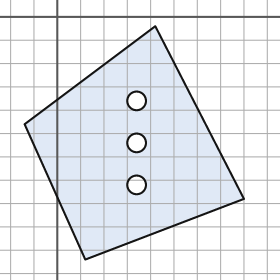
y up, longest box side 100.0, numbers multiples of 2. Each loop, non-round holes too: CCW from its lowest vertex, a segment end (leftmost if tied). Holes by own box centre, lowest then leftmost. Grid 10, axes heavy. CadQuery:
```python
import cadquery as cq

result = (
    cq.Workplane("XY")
    .moveTo(12.0, -104.0)
    .lineTo(80.0, -78.0)
    .lineTo(42.0, -4.0)
    .lineTo(-14.0, -46.0)
    .close()
    .moveTo(34.0, -72.0)
    .circle(4.0)
    .moveTo(34.0, -54.0)
    .circle(4.0)
    .moveTo(34.0, -36.0)
    .circle(4.0)
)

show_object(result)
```